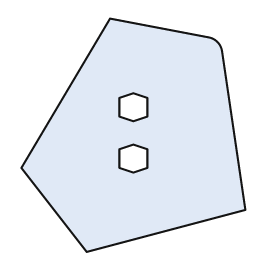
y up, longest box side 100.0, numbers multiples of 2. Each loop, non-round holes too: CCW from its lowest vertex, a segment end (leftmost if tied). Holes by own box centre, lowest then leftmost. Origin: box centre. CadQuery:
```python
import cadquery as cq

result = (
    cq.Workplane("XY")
    .moveTo(-20.0, -50.0)
    .lineTo(48.0, -32.0)
    .lineTo(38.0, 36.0)
    .threePointArc((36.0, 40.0), (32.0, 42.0))
    .lineTo(-10.0, 50.0)
    .lineTo(-48.0, -14.0)
    .close()
    .moveTo(0.0, -16.0)
    .lineTo(6.0, -14.0)
    .lineTo(6.0, -6.0)
    .lineTo(0.0, -4.0)
    .lineTo(-6.0, -6.0)
    .lineTo(-6.0, -14.0)
    .close()
    .moveTo(0.0, 6.0)
    .lineTo(6.0, 8.0)
    .lineTo(6.0, 16.0)
    .lineTo(0.0, 18.0)
    .lineTo(-6.0, 16.0)
    .lineTo(-6.0, 8.0)
    .close()
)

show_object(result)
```